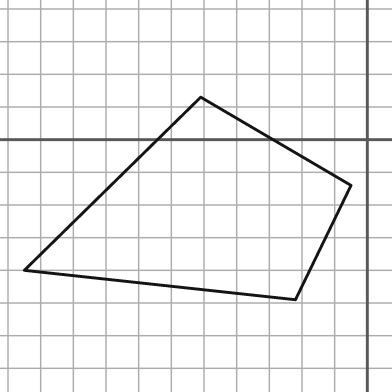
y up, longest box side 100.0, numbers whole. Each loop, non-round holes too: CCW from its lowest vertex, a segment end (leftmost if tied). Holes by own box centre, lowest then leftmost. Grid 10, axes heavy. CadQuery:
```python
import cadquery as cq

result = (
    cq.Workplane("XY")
    .moveTo(-22.0, -49.0)
    .lineTo(-5.0, -14.0)
    .lineTo(-51.0, 13.0)
    .lineTo(-105.0, -40.0)
    .close()
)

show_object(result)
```